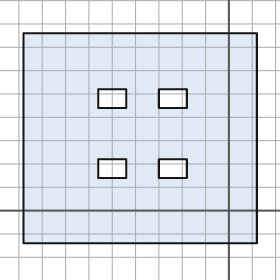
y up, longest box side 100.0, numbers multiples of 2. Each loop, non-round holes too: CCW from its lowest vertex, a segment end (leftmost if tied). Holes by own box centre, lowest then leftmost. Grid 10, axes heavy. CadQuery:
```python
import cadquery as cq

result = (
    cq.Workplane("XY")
    .moveTo(-88.0, -14.0)
    .lineTo(12.0, -14.0)
    .lineTo(12.0, 76.0)
    .lineTo(-88.0, 76.0)
    .close()
    .moveTo(-56.0, 14.0)
    .lineTo(-44.0, 14.0)
    .lineTo(-44.0, 22.0)
    .lineTo(-56.0, 22.0)
    .close()
    .moveTo(-30.0, 14.0)
    .lineTo(-18.0, 14.0)
    .lineTo(-18.0, 22.0)
    .lineTo(-30.0, 22.0)
    .close()
    .moveTo(-56.0, 44.0)
    .lineTo(-44.0, 44.0)
    .lineTo(-44.0, 52.0)
    .lineTo(-56.0, 52.0)
    .close()
    .moveTo(-30.0, 44.0)
    .lineTo(-18.0, 44.0)
    .lineTo(-18.0, 52.0)
    .lineTo(-30.0, 52.0)
    .close()
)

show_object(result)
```